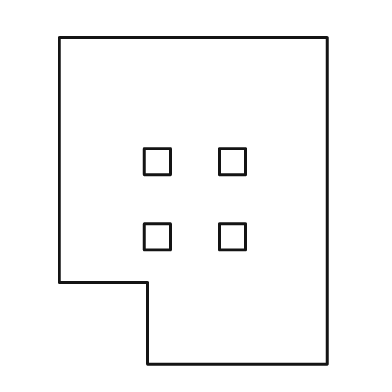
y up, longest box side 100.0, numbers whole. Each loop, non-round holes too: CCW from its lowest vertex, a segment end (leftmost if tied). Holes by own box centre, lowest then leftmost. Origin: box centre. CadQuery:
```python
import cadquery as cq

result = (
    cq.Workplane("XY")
    .moveTo(-14.0, -50.0)
    .lineTo(41.0, -50.0)
    .lineTo(41.0, 50.0)
    .lineTo(-41.0, 50.0)
    .lineTo(-41.0, -25.0)
    .lineTo(-14.0, -25.0)
    .close()
    .moveTo(-15.0, -15.0)
    .lineTo(-7.0, -15.0)
    .lineTo(-7.0, -7.0)
    .lineTo(-15.0, -7.0)
    .close()
    .moveTo(8.0, -15.0)
    .lineTo(16.0, -15.0)
    .lineTo(16.0, -7.0)
    .lineTo(8.0, -7.0)
    .close()
    .moveTo(-15.0, 8.0)
    .lineTo(-7.0, 8.0)
    .lineTo(-7.0, 16.0)
    .lineTo(-15.0, 16.0)
    .close()
    .moveTo(8.0, 8.0)
    .lineTo(16.0, 8.0)
    .lineTo(16.0, 16.0)
    .lineTo(8.0, 16.0)
    .close()
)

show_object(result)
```